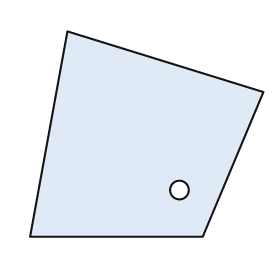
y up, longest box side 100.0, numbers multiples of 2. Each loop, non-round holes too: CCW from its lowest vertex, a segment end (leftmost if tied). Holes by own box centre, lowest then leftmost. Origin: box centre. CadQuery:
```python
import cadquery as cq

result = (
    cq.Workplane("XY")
    .moveTo(-50.0, -44.0)
    .lineTo(24.0, -44.0)
    .lineTo(50.0, 18.0)
    .lineTo(-34.0, 44.0)
    .close()
    .moveTo(14.0, -24.0)
    .circle(4.0)
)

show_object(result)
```